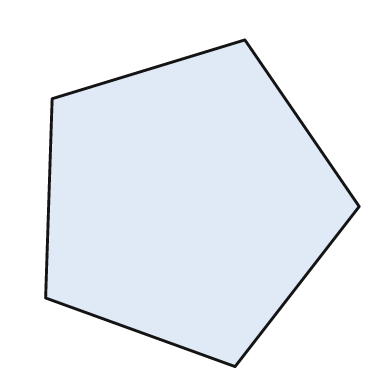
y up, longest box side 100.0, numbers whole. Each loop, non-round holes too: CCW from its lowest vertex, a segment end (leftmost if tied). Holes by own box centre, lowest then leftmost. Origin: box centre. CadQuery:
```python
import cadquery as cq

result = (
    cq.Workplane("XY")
    .moveTo(10.0, -50.0)
    .lineTo(48.0, -1.0)
    .lineTo(13.0, 50.0)
    .lineTo(-46.0, 32.0)
    .lineTo(-48.0, -29.0)
    .close()
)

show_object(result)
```